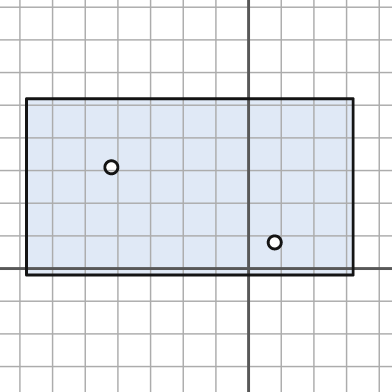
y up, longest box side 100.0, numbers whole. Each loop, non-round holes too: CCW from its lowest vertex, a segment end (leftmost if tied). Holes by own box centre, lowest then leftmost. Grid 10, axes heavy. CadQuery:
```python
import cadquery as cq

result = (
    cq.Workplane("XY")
    .moveTo(-68.0, -2.0)
    .lineTo(32.0, -2.0)
    .lineTo(32.0, 52.0)
    .lineTo(-68.0, 52.0)
    .close()
    .moveTo(8.0, 8.0)
    .circle(2.0)
    .moveTo(-42.0, 31.0)
    .circle(2.0)
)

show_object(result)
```